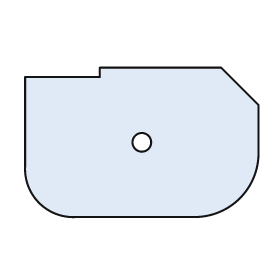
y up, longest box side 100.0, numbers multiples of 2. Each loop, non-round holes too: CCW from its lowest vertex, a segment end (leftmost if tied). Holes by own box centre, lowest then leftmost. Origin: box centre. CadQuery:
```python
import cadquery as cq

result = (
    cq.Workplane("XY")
    .moveTo(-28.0, -32.0)
    .lineTo(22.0, -32.0)
    .threePointArc((42.0, -24.0), (50.0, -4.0))
    .lineTo(50.0, 16.0)
    .lineTo(34.0, 32.0)
    .lineTo(-18.0, 32.0)
    .lineTo(-18.0, 28.0)
    .lineTo(-50.0, 28.0)
    .lineTo(-50.0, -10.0)
    .threePointArc((-44.0, -26.0), (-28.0, -32.0))
    .close()
    .moveTo(0.0, 0.0)
    .circle(4.0)
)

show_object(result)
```